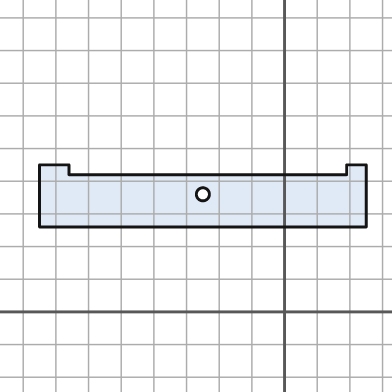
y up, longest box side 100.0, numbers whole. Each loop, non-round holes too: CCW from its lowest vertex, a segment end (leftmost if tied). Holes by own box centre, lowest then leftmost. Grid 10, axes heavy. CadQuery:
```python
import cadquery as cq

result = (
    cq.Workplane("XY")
    .moveTo(-75.0, 26.0)
    .lineTo(25.0, 26.0)
    .lineTo(25.0, 45.0)
    .lineTo(19.0, 45.0)
    .lineTo(19.0, 42.0)
    .lineTo(-66.0, 42.0)
    .lineTo(-66.0, 45.0)
    .lineTo(-75.0, 45.0)
    .close()
    .moveTo(-25.0, 36.0)
    .circle(2.0)
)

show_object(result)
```